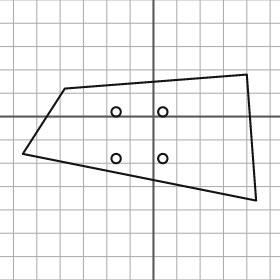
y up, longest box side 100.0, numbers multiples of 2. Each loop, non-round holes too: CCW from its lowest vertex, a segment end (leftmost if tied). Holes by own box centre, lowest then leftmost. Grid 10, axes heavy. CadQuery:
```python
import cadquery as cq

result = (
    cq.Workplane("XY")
    .moveTo(44.0, -36.0)
    .lineTo(40.0, 18.0)
    .lineTo(-38.0, 12.0)
    .lineTo(-56.0, -16.0)
    .close()
    .moveTo(-16.0, -18.0)
    .circle(2.0)
    .moveTo(4.0, -18.0)
    .circle(2.0)
    .moveTo(-16.0, 2.0)
    .circle(2.0)
    .moveTo(4.0, 2.0)
    .circle(2.0)
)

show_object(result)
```